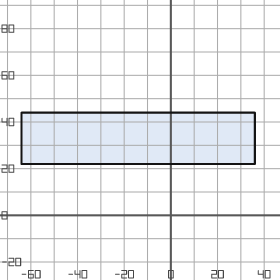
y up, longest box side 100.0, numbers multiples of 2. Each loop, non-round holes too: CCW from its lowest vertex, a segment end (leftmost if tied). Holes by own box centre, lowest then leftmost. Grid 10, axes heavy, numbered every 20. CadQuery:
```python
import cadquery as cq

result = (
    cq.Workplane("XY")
    .moveTo(-64.0, 22.0)
    .lineTo(36.0, 22.0)
    .lineTo(36.0, 44.0)
    .lineTo(-64.0, 44.0)
    .close()
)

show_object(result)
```